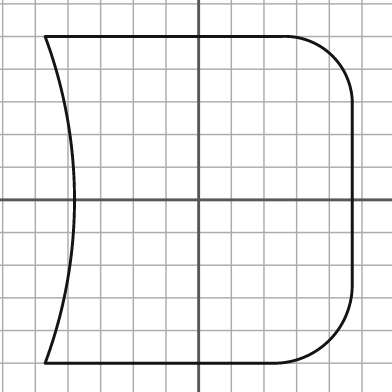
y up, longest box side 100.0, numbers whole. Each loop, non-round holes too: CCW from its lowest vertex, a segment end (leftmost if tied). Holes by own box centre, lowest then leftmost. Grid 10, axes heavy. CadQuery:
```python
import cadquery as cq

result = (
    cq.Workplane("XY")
    .moveTo(-47.0, -50.0)
    .lineTo(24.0, -50.0)
    .threePointArc((40.0, -43.0), (47.0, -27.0))
    .lineTo(47.0, 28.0)
    .threePointArc((41.0, 44.0), (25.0, 50.0))
    .lineTo(-47.0, 50.0)
    .threePointArc((-38.0, 0.0), (-47.0, -50.0))
    .close()
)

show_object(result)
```